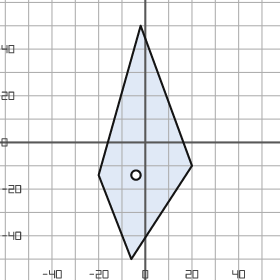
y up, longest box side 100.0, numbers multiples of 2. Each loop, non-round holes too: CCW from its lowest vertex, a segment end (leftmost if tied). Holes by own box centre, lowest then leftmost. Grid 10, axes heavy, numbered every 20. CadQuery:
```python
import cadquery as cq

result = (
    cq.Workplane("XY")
    .moveTo(-6.0, -50.0)
    .lineTo(20.0, -10.0)
    .lineTo(-2.0, 50.0)
    .lineTo(-20.0, -14.0)
    .close()
    .moveTo(-4.0, -14.0)
    .circle(2.0)
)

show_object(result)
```